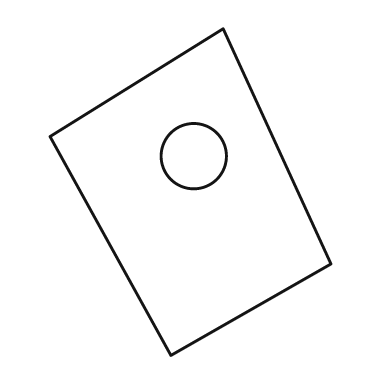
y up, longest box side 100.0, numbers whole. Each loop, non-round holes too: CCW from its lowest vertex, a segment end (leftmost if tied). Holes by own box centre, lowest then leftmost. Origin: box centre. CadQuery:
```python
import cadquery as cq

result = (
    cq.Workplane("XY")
    .moveTo(-6.0, -50.0)
    .lineTo(43.0, -22.0)
    .lineTo(10.0, 50.0)
    .lineTo(-43.0, 17.0)
    .close()
    .moveTo(1.0, 11.0)
    .circle(10.0)
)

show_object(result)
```